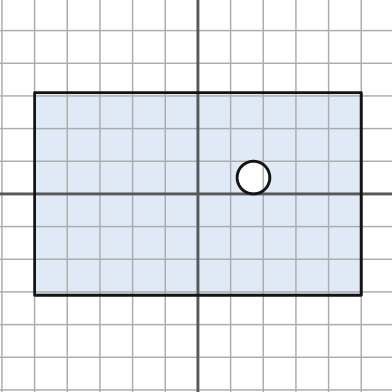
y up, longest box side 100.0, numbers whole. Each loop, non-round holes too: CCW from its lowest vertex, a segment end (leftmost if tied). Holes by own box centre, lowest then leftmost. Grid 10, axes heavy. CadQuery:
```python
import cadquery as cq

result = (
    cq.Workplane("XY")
    .moveTo(-50.0, -31.0)
    .lineTo(50.0, -31.0)
    .lineTo(50.0, 31.0)
    .lineTo(-50.0, 31.0)
    .close()
    .moveTo(17.0, 5.0)
    .circle(5.0)
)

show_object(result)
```